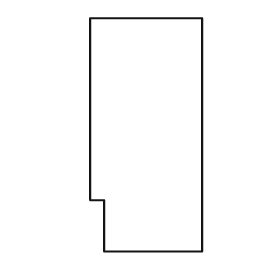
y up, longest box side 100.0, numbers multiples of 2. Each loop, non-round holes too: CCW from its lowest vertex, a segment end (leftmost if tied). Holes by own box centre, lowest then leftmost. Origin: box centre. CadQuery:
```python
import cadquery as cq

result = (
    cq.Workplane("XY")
    .moveTo(-18.0, -50.0)
    .lineTo(24.0, -50.0)
    .lineTo(24.0, 50.0)
    .lineTo(-24.0, 50.0)
    .lineTo(-24.0, -28.0)
    .lineTo(-18.0, -28.0)
    .close()
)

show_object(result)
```